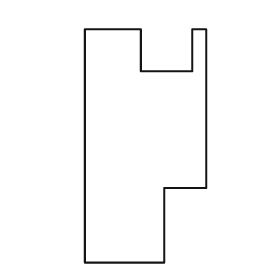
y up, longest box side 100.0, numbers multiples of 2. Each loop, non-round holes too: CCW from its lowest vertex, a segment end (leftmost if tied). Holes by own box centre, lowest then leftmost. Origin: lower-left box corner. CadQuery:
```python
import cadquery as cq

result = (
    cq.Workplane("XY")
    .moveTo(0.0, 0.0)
    .lineTo(34.0, 0.0)
    .lineTo(34.0, 32.0)
    .lineTo(52.0, 32.0)
    .lineTo(52.0, 100.0)
    .lineTo(46.0, 100.0)
    .lineTo(46.0, 82.0)
    .lineTo(24.0, 82.0)
    .lineTo(24.0, 100.0)
    .lineTo(0.0, 100.0)
    .close()
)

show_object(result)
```